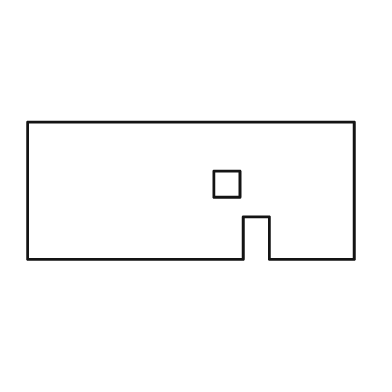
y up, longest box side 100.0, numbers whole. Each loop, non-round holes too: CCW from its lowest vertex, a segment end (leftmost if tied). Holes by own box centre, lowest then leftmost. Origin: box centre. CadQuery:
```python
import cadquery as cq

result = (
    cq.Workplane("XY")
    .moveTo(-50.0, -21.0)
    .lineTo(16.0, -21.0)
    .lineTo(16.0, -8.0)
    .lineTo(24.0, -8.0)
    .lineTo(24.0, -21.0)
    .lineTo(50.0, -21.0)
    .lineTo(50.0, 21.0)
    .lineTo(-50.0, 21.0)
    .close()
    .moveTo(7.0, -2.0)
    .lineTo(15.0, -2.0)
    .lineTo(15.0, 6.0)
    .lineTo(7.0, 6.0)
    .close()
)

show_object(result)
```